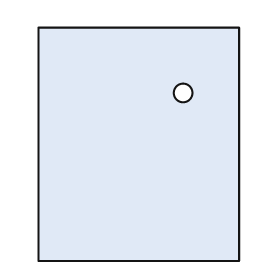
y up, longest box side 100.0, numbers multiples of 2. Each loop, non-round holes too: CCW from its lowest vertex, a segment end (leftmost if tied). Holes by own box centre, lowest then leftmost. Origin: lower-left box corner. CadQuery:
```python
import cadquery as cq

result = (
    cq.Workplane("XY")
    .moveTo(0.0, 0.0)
    .lineTo(86.0, 0.0)
    .lineTo(86.0, 100.0)
    .lineTo(0.0, 100.0)
    .close()
    .moveTo(62.0, 72.0)
    .circle(4.0)
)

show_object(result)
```